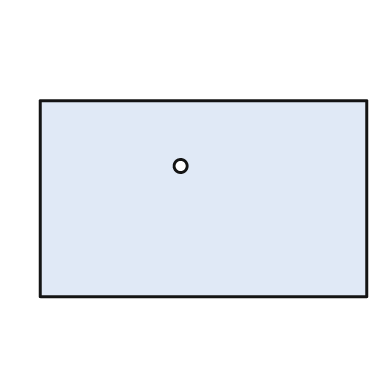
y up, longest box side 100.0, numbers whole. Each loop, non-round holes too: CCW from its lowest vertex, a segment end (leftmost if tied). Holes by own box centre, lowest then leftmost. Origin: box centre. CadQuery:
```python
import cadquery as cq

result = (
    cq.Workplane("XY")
    .moveTo(-50.0, -30.0)
    .lineTo(50.0, -30.0)
    .lineTo(50.0, 30.0)
    .lineTo(-50.0, 30.0)
    .close()
    .moveTo(-7.0, 10.0)
    .circle(2.0)
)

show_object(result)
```